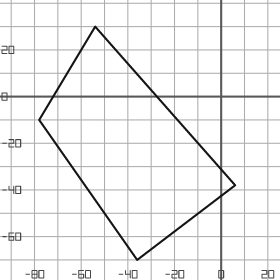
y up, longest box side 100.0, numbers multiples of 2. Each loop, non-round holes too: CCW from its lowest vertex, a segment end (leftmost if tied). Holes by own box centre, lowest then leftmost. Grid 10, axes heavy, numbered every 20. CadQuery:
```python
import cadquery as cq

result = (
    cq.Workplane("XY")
    .moveTo(-36.0, -70.0)
    .lineTo(6.0, -38.0)
    .lineTo(-54.0, 30.0)
    .lineTo(-78.0, -10.0)
    .close()
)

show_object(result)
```